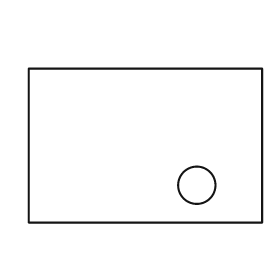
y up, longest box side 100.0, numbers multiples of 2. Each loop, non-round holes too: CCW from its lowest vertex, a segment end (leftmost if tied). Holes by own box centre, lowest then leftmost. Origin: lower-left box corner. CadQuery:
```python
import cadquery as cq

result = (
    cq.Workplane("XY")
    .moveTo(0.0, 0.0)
    .lineTo(100.0, 0.0)
    .lineTo(100.0, 66.0)
    .lineTo(0.0, 66.0)
    .close()
    .moveTo(72.0, 16.0)
    .circle(8.0)
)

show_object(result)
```